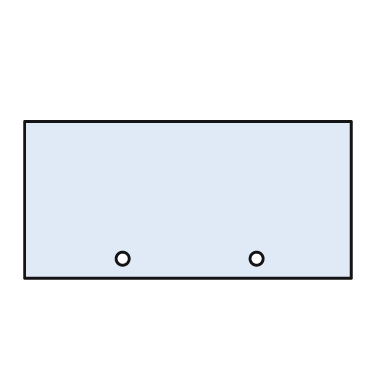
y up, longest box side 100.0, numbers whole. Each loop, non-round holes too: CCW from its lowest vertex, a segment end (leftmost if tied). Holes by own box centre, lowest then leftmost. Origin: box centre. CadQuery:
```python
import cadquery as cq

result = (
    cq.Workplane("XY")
    .moveTo(-50.0, -24.0)
    .lineTo(50.0, -24.0)
    .lineTo(50.0, 24.0)
    .lineTo(-50.0, 24.0)
    .close()
    .moveTo(-20.0, -18.0)
    .circle(2.0)
    .moveTo(21.0, -18.0)
    .circle(2.0)
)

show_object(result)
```